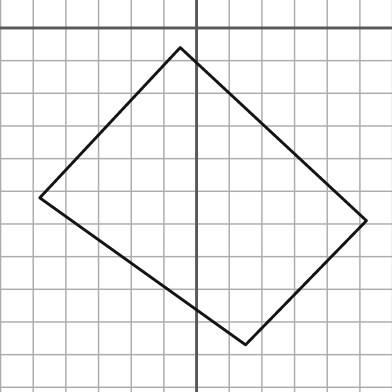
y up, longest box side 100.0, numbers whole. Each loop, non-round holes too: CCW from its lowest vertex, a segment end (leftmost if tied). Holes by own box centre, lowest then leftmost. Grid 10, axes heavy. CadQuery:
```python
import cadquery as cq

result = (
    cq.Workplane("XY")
    .moveTo(15.0, -97.0)
    .lineTo(52.0, -59.0)
    .lineTo(-5.0, -6.0)
    .lineTo(-48.0, -52.0)
    .close()
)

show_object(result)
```